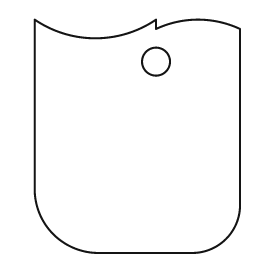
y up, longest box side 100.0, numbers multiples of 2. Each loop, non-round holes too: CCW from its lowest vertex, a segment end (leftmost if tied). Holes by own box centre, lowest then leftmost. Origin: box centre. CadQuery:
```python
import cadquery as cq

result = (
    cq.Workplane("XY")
    .moveTo(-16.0, -50.0)
    .lineTo(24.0, -50.0)
    .threePointArc((38.0, -44.0), (44.0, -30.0))
    .lineTo(44.0, 46.0)
    .threePointArc((26.0, 50.0), (8.0, 46.0))
    .lineTo(8.0, 50.0)
    .threePointArc((-18.0, 42.0), (-44.0, 50.0))
    .lineTo(-44.0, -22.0)
    .threePointArc((-36.0, -42.0), (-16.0, -50.0))
    .close()
    .moveTo(8.0, 32.0)
    .circle(6.0)
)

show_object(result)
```